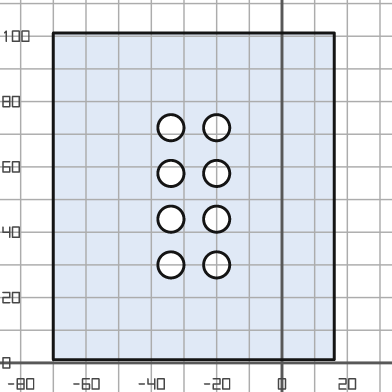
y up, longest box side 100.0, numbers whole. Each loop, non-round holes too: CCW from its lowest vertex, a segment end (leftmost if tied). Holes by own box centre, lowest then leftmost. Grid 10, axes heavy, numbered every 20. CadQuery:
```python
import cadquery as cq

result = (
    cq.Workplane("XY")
    .moveTo(-70.0, 1.0)
    .lineTo(16.0, 1.0)
    .lineTo(16.0, 101.0)
    .lineTo(-70.0, 101.0)
    .close()
    .moveTo(-34.0, 30.0)
    .circle(4.0)
    .moveTo(-20.0, 30.0)
    .circle(4.0)
    .moveTo(-34.0, 44.0)
    .circle(4.0)
    .moveTo(-20.0, 44.0)
    .circle(4.0)
    .moveTo(-34.0, 58.0)
    .circle(4.0)
    .moveTo(-20.0, 58.0)
    .circle(4.0)
    .moveTo(-34.0, 72.0)
    .circle(4.0)
    .moveTo(-20.0, 72.0)
    .circle(4.0)
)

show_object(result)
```